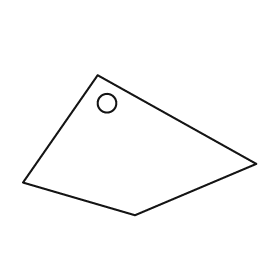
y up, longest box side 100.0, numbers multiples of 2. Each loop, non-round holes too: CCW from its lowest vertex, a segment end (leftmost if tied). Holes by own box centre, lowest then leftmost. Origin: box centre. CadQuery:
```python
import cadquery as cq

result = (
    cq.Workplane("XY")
    .moveTo(-2.0, -30.0)
    .lineTo(50.0, -8.0)
    .lineTo(-18.0, 30.0)
    .lineTo(-50.0, -16.0)
    .close()
    .moveTo(-14.0, 18.0)
    .circle(4.0)
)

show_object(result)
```